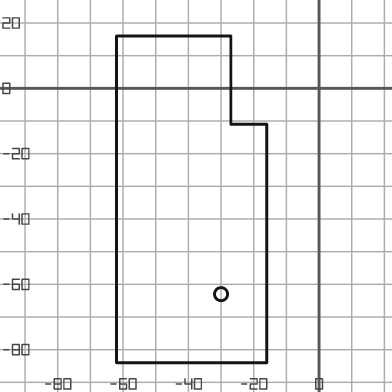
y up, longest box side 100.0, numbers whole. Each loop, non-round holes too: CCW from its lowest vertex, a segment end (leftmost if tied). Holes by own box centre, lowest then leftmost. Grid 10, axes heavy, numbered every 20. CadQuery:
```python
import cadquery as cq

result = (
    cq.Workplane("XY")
    .moveTo(-62.0, -84.0)
    .lineTo(-16.0, -84.0)
    .lineTo(-16.0, -11.0)
    .lineTo(-27.0, -11.0)
    .lineTo(-27.0, 16.0)
    .lineTo(-62.0, 16.0)
    .close()
    .moveTo(-30.0, -63.0)
    .circle(2.0)
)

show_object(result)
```